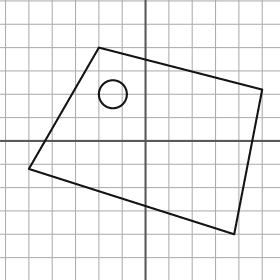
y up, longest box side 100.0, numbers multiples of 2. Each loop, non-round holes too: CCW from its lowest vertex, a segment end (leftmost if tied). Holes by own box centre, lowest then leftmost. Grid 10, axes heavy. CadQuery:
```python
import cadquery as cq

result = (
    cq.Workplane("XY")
    .moveTo(38.0, -40.0)
    .lineTo(50.0, 22.0)
    .lineTo(-20.0, 40.0)
    .lineTo(-50.0, -12.0)
    .close()
    .moveTo(-14.0, 20.0)
    .circle(6.0)
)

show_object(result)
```